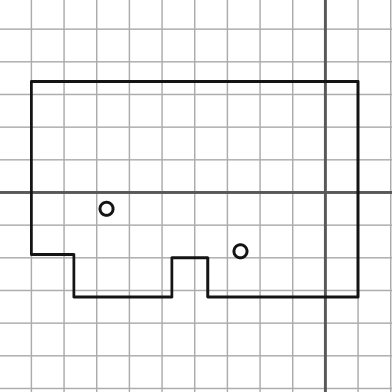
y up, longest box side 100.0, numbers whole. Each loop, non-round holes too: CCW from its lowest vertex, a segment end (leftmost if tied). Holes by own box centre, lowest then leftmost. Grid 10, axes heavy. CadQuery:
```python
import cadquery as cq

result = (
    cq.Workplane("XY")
    .moveTo(-77.0, -32.0)
    .lineTo(-47.0, -32.0)
    .lineTo(-47.0, -20.0)
    .lineTo(-36.0, -20.0)
    .lineTo(-36.0, -32.0)
    .lineTo(10.0, -32.0)
    .lineTo(10.0, 34.0)
    .lineTo(-90.0, 34.0)
    .lineTo(-90.0, -19.0)
    .lineTo(-77.0, -19.0)
    .close()
    .moveTo(-26.0, -18.0)
    .circle(2.0)
    .moveTo(-67.0, -5.0)
    .circle(2.0)
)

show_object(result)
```